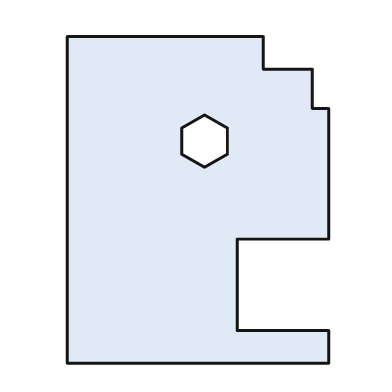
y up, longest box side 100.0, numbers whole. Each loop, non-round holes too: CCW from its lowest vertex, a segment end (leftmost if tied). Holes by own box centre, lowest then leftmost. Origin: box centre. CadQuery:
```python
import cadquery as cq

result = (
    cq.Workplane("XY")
    .moveTo(-40.0, -50.0)
    .lineTo(40.0, -50.0)
    .lineTo(40.0, -40.0)
    .lineTo(12.0, -40.0)
    .lineTo(12.0, -12.0)
    .lineTo(40.0, -12.0)
    .lineTo(40.0, 28.0)
    .lineTo(35.0, 28.0)
    .lineTo(35.0, 40.0)
    .lineTo(20.0, 40.0)
    .lineTo(20.0, 50.0)
    .lineTo(-40.0, 50.0)
    .close()
    .moveTo(2.0, 10.0)
    .lineTo(9.0, 14.0)
    .lineTo(9.0, 22.0)
    .lineTo(2.0, 26.0)
    .lineTo(-5.0, 22.0)
    .lineTo(-5.0, 14.0)
    .close()
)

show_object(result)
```